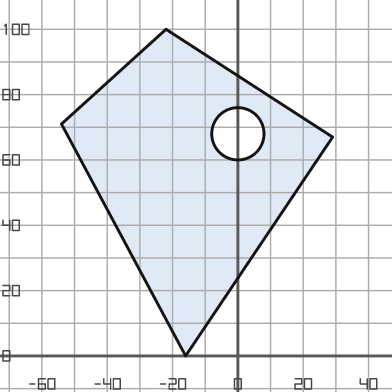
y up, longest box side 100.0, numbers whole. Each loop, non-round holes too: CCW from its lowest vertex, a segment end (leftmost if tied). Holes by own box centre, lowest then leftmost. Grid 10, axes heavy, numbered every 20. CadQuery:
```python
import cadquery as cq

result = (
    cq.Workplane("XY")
    .moveTo(-16.0, 0.0)
    .lineTo(29.0, 67.0)
    .lineTo(-22.0, 100.0)
    .lineTo(-54.0, 71.0)
    .close()
    .moveTo(0.0, 68.0)
    .circle(8.0)
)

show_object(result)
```